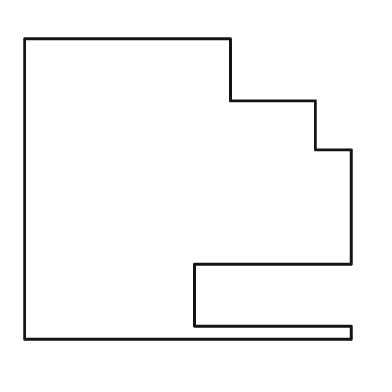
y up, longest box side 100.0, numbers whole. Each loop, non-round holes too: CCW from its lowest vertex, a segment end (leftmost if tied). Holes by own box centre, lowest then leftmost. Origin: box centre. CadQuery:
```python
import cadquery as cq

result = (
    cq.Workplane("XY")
    .moveTo(-50.0, -46.0)
    .lineTo(50.0, -46.0)
    .lineTo(50.0, -42.0)
    .lineTo(2.0, -42.0)
    .lineTo(2.0, -23.0)
    .lineTo(50.0, -23.0)
    .lineTo(50.0, 12.0)
    .lineTo(39.0, 12.0)
    .lineTo(39.0, 27.0)
    .lineTo(13.0, 27.0)
    .lineTo(13.0, 46.0)
    .lineTo(-50.0, 46.0)
    .close()
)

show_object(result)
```